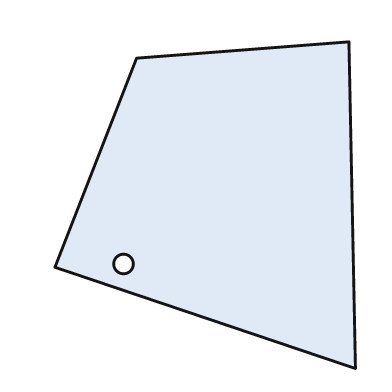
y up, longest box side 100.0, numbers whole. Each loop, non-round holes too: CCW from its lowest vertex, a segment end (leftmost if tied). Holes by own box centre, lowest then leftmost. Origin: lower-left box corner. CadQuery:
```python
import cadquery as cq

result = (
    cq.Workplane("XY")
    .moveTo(92.0, 0.0)
    .lineTo(90.0, 100.0)
    .lineTo(25.0, 95.0)
    .lineTo(0.0, 31.0)
    .close()
    .moveTo(21.0, 32.0)
    .circle(3.0)
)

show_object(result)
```